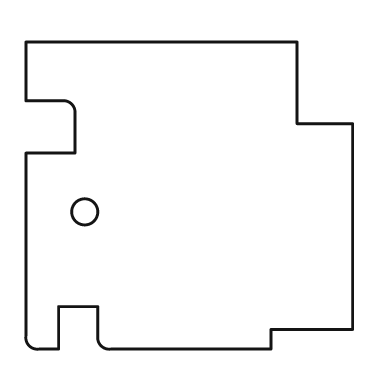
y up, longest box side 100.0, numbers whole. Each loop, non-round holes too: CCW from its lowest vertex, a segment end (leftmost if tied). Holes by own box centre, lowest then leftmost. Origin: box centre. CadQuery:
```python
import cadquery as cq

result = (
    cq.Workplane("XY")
    .moveTo(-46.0, -47.0)
    .lineTo(-40.0, -47.0)
    .lineTo(-40.0, -34.0)
    .lineTo(-28.0, -34.0)
    .lineTo(-28.0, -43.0)
    .threePointArc((-27.0, -46.0), (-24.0, -47.0))
    .lineTo(25.0, -47.0)
    .lineTo(25.0, -41.0)
    .lineTo(50.0, -41.0)
    .lineTo(50.0, 22.0)
    .lineTo(33.0, 22.0)
    .lineTo(33.0, 47.0)
    .lineTo(-50.0, 47.0)
    .lineTo(-50.0, 29.0)
    .lineTo(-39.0, 29.0)
    .threePointArc((-36.0, 28.0), (-35.0, 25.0))
    .lineTo(-35.0, 13.0)
    .lineTo(-50.0, 13.0)
    .lineTo(-50.0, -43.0)
    .threePointArc((-49.0, -46.0), (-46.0, -47.0))
    .close()
    .moveTo(-32.0, -5.0)
    .circle(4.0)
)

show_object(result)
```